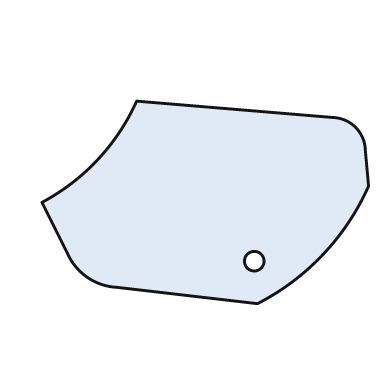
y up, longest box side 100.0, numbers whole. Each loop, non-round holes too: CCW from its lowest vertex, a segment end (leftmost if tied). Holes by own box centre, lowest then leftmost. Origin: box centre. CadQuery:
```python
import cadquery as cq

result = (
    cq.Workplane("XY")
    .moveTo(16.0, -31.0)
    .threePointArc((36.0, -16.0), (50.0, 5.0))
    .lineTo(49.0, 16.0)
    .threePointArc((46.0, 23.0), (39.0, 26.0))
    .lineTo(-21.0, 31.0)
    .threePointArc((-33.0, 13.0), (-50.0, 0.0))
    .lineTo(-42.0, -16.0)
    .threePointArc((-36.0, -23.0), (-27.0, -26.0))
    .close()
    .moveTo(15.0, -18.0)
    .circle(3.0)
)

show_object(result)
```